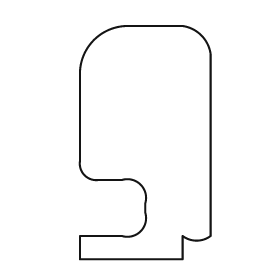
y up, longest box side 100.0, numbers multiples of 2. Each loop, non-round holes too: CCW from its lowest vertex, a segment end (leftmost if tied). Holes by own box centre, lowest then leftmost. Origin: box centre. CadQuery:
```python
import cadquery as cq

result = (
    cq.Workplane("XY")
    .moveTo(-28.0, -50.0)
    .lineTo(16.0, -50.0)
    .lineTo(16.0, -40.0)
    .threePointArc((22.0, -42.0), (28.0, -40.0))
    .lineTo(28.0, 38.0)
    .threePointArc((24.0, 46.0), (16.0, 50.0))
    .lineTo(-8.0, 50.0)
    .threePointArc((-22.0, 44.0), (-28.0, 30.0))
    .lineTo(-28.0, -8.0)
    .threePointArc((-26.0, -14.0), (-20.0, -16.0))
    .lineTo(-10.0, -16.0)
    .threePointArc((-2.0, -18.0), (0.0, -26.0))
    .lineTo(0.0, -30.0)
    .threePointArc((-2.0, -38.0), (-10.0, -40.0))
    .lineTo(-28.0, -40.0)
    .close()
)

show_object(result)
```